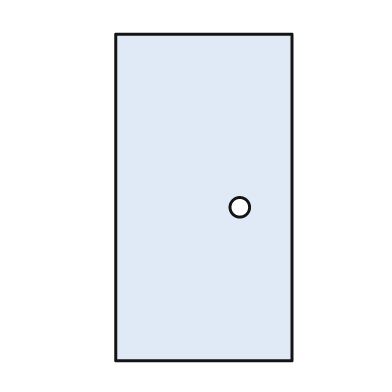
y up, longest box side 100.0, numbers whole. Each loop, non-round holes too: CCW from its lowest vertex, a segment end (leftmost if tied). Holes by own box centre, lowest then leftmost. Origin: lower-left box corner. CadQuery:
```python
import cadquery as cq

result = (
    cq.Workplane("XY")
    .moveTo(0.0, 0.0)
    .lineTo(54.0, 0.0)
    .lineTo(54.0, 100.0)
    .lineTo(0.0, 100.0)
    .close()
    .moveTo(38.0, 47.0)
    .circle(3.0)
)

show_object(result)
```